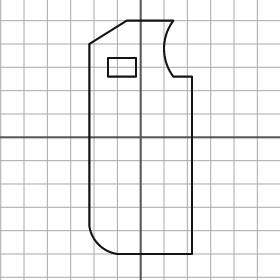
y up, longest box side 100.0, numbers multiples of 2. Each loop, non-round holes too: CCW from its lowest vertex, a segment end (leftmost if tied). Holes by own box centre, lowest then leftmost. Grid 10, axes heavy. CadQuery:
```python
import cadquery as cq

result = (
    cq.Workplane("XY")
    .moveTo(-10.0, -50.0)
    .lineTo(22.0, -50.0)
    .lineTo(22.0, 26.0)
    .lineTo(14.0, 26.0)
    .threePointArc((10.0, 38.0), (14.0, 50.0))
    .lineTo(-6.0, 50.0)
    .lineTo(-22.0, 40.0)
    .lineTo(-22.0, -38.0)
    .threePointArc((-18.0, -46.0), (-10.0, -50.0))
    .close()
    .moveTo(-14.0, 26.0)
    .lineTo(-2.0, 26.0)
    .lineTo(-2.0, 34.0)
    .lineTo(-14.0, 34.0)
    .close()
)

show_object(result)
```